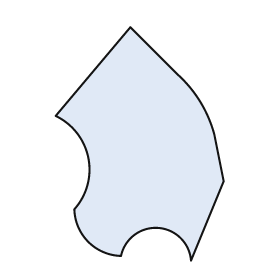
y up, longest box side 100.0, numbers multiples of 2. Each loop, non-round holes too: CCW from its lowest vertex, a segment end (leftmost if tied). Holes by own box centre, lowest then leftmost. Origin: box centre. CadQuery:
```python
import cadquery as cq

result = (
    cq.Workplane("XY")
    .moveTo(22.0, -50.0)
    .lineTo(36.0, -16.0)
    .lineTo(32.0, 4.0)
    .threePointArc((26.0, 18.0), (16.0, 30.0))
    .lineTo(-4.0, 50.0)
    .lineTo(-36.0, 12.0)
    .threePointArc((-22.0, -6.0), (-28.0, -28.0))
    .threePointArc((-22.0, -42.0), (-8.0, -48.0))
    .threePointArc((8.0, -36.0), (22.0, -50.0))
    .close()
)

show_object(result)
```